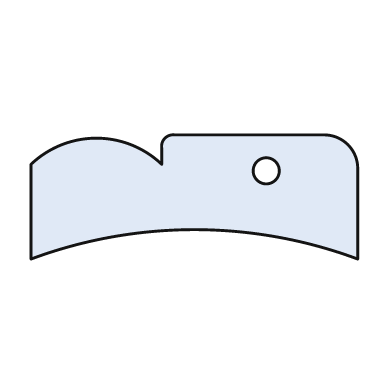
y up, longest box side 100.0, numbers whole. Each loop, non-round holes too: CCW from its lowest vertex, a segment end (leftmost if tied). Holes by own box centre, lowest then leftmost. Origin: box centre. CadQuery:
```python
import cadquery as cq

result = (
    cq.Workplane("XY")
    .moveTo(-50.0, -19.0)
    .threePointArc((0.0, -10.0), (50.0, -19.0))
    .lineTo(50.0, 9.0)
    .threePointArc((47.0, 16.0), (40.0, 19.0))
    .lineTo(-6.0, 19.0)
    .threePointArc((-9.0, 18.0), (-10.0, 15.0))
    .lineTo(-10.0, 10.0)
    .threePointArc((-30.0, 18.0), (-50.0, 10.0))
    .close()
    .moveTo(22.0, 8.0)
    .circle(4.0)
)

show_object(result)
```